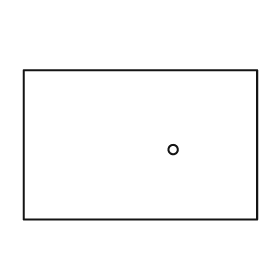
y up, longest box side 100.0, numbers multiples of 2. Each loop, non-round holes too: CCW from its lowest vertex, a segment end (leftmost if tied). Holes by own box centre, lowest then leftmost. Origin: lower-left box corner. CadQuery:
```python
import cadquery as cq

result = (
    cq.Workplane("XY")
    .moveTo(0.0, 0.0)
    .lineTo(100.0, 0.0)
    .lineTo(100.0, 64.0)
    .lineTo(0.0, 64.0)
    .close()
    .moveTo(64.0, 30.0)
    .circle(2.0)
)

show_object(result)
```